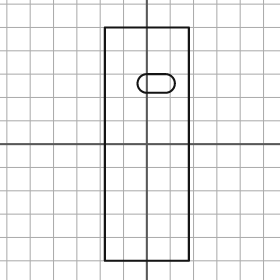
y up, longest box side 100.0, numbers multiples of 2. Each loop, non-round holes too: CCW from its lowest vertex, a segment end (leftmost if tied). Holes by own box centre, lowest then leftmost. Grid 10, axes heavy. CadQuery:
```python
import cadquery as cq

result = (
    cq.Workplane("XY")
    .moveTo(-18.0, -50.0)
    .lineTo(18.0, -50.0)
    .lineTo(18.0, 50.0)
    .lineTo(-18.0, 50.0)
    .close()
    .moveTo(0.0, 22.0)
    .lineTo(8.0, 22.0)
    .threePointArc((12.0, 26.0), (8.0, 30.0))
    .lineTo(0.0, 30.0)
    .threePointArc((-4.0, 26.0), (0.0, 22.0))
    .close()
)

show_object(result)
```